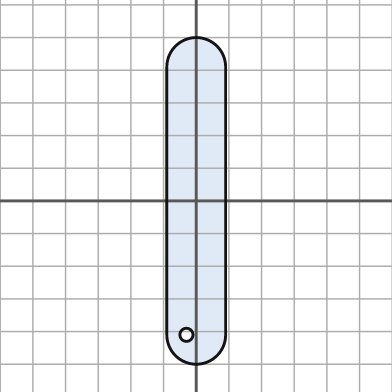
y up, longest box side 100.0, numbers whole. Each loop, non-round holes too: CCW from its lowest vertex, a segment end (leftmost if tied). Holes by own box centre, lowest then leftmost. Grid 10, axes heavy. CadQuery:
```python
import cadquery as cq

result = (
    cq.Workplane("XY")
    .moveTo(-9.0, -41.0)
    .threePointArc((0.0, -50.0), (9.0, -41.0))
    .lineTo(9.0, 41.0)
    .threePointArc((0.0, 50.0), (-9.0, 41.0))
    .close()
    .moveTo(-3.0, -41.0)
    .circle(2.0)
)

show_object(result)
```